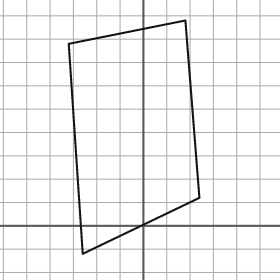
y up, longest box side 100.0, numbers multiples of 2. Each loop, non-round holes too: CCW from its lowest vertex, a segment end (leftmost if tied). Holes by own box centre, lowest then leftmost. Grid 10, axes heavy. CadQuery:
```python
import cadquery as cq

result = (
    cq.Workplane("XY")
    .moveTo(-26.0, -12.0)
    .lineTo(24.0, 12.0)
    .lineTo(18.0, 88.0)
    .lineTo(-32.0, 78.0)
    .close()
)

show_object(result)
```